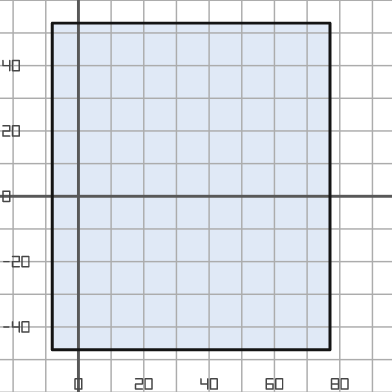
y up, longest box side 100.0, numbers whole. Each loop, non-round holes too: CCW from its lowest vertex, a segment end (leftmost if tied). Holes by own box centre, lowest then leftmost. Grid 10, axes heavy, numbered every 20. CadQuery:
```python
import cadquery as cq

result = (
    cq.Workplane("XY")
    .moveTo(-8.0, -47.0)
    .lineTo(77.0, -47.0)
    .lineTo(77.0, 53.0)
    .lineTo(-8.0, 53.0)
    .close()
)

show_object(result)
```